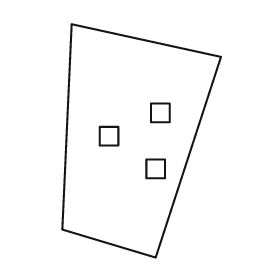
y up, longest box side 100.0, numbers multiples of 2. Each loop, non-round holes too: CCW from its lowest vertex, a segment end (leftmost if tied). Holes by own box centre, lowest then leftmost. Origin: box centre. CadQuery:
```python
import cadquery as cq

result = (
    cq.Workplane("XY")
    .moveTo(6.0, -50.0)
    .lineTo(34.0, 36.0)
    .lineTo(-30.0, 50.0)
    .lineTo(-34.0, -38.0)
    .close()
    .moveTo(2.0, -16.0)
    .lineTo(10.0, -16.0)
    .lineTo(10.0, -8.0)
    .lineTo(2.0, -8.0)
    .close()
    .moveTo(-18.0, -2.0)
    .lineTo(-10.0, -2.0)
    .lineTo(-10.0, 6.0)
    .lineTo(-18.0, 6.0)
    .close()
    .moveTo(4.0, 8.0)
    .lineTo(12.0, 8.0)
    .lineTo(12.0, 16.0)
    .lineTo(4.0, 16.0)
    .close()
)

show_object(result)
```